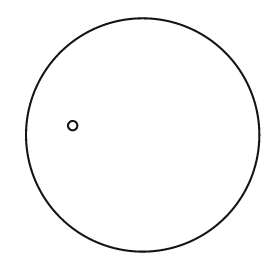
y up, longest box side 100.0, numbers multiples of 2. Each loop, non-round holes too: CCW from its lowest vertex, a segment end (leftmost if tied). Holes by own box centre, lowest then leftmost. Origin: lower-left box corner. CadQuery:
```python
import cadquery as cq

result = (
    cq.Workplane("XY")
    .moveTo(50.0, 50.0)
    .circle(50.0)
    .moveTo(20.0, 54.0)
    .circle(2.0)
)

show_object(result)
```